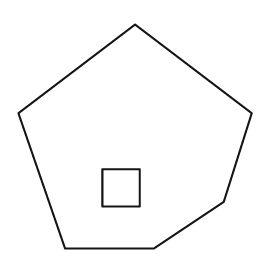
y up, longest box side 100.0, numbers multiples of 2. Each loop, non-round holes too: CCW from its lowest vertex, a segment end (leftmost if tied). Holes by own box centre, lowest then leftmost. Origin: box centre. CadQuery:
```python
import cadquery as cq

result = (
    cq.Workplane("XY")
    .moveTo(-30.0, -48.0)
    .lineTo(8.0, -48.0)
    .lineTo(38.0, -28.0)
    .lineTo(50.0, 10.0)
    .lineTo(0.0, 48.0)
    .lineTo(-50.0, 10.0)
    .close()
    .moveTo(-14.0, -30.0)
    .lineTo(2.0, -30.0)
    .lineTo(2.0, -14.0)
    .lineTo(-14.0, -14.0)
    .close()
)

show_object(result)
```